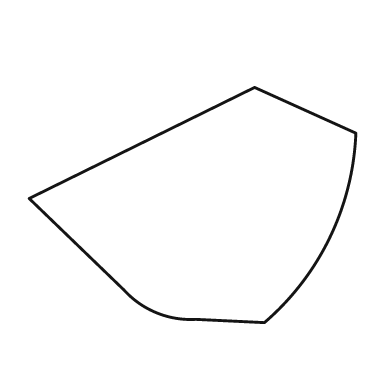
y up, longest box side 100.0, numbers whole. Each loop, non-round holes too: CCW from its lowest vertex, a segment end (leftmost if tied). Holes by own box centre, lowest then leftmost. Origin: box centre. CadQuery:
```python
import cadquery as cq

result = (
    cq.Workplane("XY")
    .moveTo(22.0, -36.0)
    .threePointArc((42.0, -10.0), (50.0, 22.0))
    .lineTo(19.0, 36.0)
    .lineTo(-50.0, 2.0)
    .lineTo(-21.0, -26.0)
    .threePointArc((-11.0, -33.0), (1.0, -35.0))
    .close()
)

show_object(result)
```